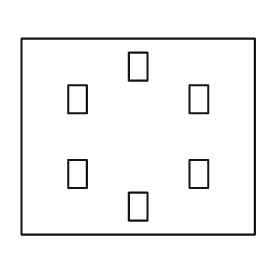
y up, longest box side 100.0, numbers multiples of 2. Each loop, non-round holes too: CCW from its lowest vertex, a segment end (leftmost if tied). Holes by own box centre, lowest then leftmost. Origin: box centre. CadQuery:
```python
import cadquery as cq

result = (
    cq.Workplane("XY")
    .moveTo(-50.0, -42.0)
    .lineTo(50.0, -42.0)
    .lineTo(50.0, 42.0)
    .lineTo(-50.0, 42.0)
    .close()
    .moveTo(-4.0, -36.0)
    .lineTo(4.0, -36.0)
    .lineTo(4.0, -24.0)
    .lineTo(-4.0, -24.0)
    .close()
    .moveTo(-30.0, -22.0)
    .lineTo(-22.0, -22.0)
    .lineTo(-22.0, -10.0)
    .lineTo(-30.0, -10.0)
    .close()
    .moveTo(22.0, -22.0)
    .lineTo(30.0, -22.0)
    .lineTo(30.0, -10.0)
    .lineTo(22.0, -10.0)
    .close()
    .moveTo(-30.0, 10.0)
    .lineTo(-22.0, 10.0)
    .lineTo(-22.0, 22.0)
    .lineTo(-30.0, 22.0)
    .close()
    .moveTo(22.0, 10.0)
    .lineTo(30.0, 10.0)
    .lineTo(30.0, 22.0)
    .lineTo(22.0, 22.0)
    .close()
    .moveTo(-4.0, 24.0)
    .lineTo(4.0, 24.0)
    .lineTo(4.0, 36.0)
    .lineTo(-4.0, 36.0)
    .close()
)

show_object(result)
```